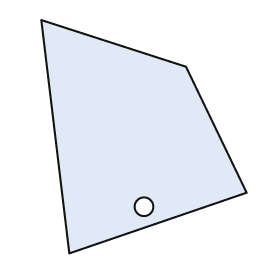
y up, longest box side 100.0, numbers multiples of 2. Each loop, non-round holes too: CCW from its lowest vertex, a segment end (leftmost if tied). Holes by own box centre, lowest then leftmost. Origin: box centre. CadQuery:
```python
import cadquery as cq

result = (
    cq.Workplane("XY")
    .moveTo(-32.0, -50.0)
    .lineTo(44.0, -24.0)
    .lineTo(18.0, 30.0)
    .lineTo(-44.0, 50.0)
    .close()
    .moveTo(0.0, -30.0)
    .circle(4.0)
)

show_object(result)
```